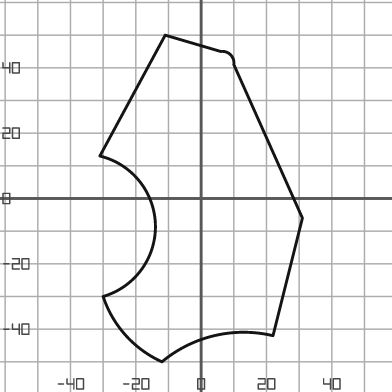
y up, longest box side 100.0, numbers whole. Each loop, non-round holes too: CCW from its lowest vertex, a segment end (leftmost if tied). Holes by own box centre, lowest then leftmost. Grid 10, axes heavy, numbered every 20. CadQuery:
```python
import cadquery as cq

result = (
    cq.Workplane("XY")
    .moveTo(-12.0, -50.0)
    .threePointArc((4.0, -42.0), (22.0, -42.0))
    .lineTo(31.0, -6.0)
    .lineTo(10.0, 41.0)
    .threePointArc((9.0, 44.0), (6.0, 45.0))
    .lineTo(-11.0, 50.0)
    .lineTo(-31.0, 13.0)
    .threePointArc((-14.0, -8.0), (-30.0, -30.0))
    .threePointArc((-23.0, -42.0), (-12.0, -50.0))
    .close()
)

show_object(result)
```